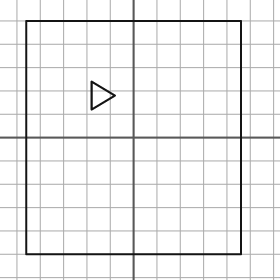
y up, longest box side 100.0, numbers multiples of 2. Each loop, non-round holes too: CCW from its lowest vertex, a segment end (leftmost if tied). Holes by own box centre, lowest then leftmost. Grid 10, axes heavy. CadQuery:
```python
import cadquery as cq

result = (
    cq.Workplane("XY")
    .moveTo(-46.0, -50.0)
    .lineTo(46.0, -50.0)
    .lineTo(46.0, 50.0)
    .lineTo(-46.0, 50.0)
    .close()
    .moveTo(-18.0, 12.0)
    .lineTo(-8.0, 18.0)
    .lineTo(-18.0, 24.0)
    .close()
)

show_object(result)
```